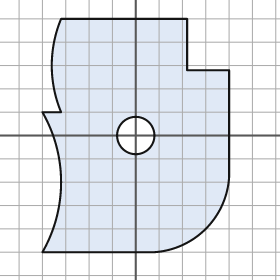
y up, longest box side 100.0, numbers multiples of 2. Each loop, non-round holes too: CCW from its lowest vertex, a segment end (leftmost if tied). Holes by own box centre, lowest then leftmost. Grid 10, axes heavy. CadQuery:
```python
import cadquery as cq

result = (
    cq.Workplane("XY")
    .moveTo(-40.0, -50.0)
    .lineTo(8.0, -50.0)
    .threePointArc((30.0, -40.0), (40.0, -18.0))
    .lineTo(40.0, 28.0)
    .lineTo(22.0, 28.0)
    .lineTo(22.0, 50.0)
    .lineTo(-32.0, 50.0)
    .threePointArc((-36.0, 30.0), (-32.0, 10.0))
    .lineTo(-40.0, 10.0)
    .threePointArc((-32.0, -20.0), (-40.0, -50.0))
    .close()
    .moveTo(0.0, 0.0)
    .circle(8.0)
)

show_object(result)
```